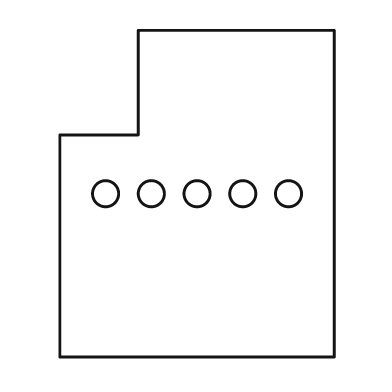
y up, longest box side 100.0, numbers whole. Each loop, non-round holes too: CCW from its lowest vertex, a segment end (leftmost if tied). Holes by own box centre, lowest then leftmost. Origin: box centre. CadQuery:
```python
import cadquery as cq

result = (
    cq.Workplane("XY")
    .moveTo(-42.0, -50.0)
    .lineTo(42.0, -50.0)
    .lineTo(42.0, 50.0)
    .lineTo(-18.0, 50.0)
    .lineTo(-18.0, 18.0)
    .lineTo(-42.0, 18.0)
    .close()
    .moveTo(-28.0, 0.0)
    .circle(4.0)
    .moveTo(-14.0, 0.0)
    .circle(4.0)
    .moveTo(0.0, 0.0)
    .circle(4.0)
    .moveTo(14.0, 0.0)
    .circle(4.0)
    .moveTo(28.0, 0.0)
    .circle(4.0)
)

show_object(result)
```